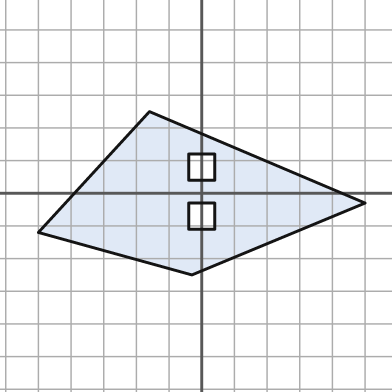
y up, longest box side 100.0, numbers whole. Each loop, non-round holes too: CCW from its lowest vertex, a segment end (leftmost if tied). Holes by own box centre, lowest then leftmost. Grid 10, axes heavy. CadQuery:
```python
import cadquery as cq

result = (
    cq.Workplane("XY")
    .moveTo(-3.0, -25.0)
    .lineTo(50.0, -3.0)
    .lineTo(-16.0, 25.0)
    .lineTo(-50.0, -12.0)
    .close()
    .moveTo(-4.0, -11.0)
    .lineTo(4.0, -11.0)
    .lineTo(4.0, -3.0)
    .lineTo(-4.0, -3.0)
    .close()
    .moveTo(-4.0, 4.0)
    .lineTo(4.0, 4.0)
    .lineTo(4.0, 12.0)
    .lineTo(-4.0, 12.0)
    .close()
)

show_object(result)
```